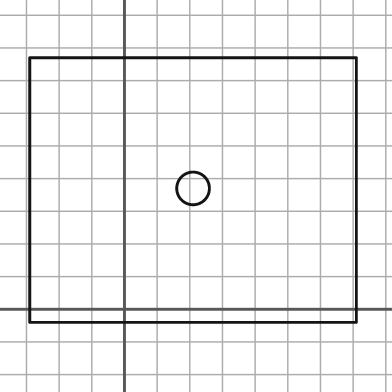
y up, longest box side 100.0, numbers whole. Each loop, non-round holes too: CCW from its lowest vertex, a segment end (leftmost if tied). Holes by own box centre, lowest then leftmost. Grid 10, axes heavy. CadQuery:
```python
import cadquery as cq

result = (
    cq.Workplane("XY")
    .moveTo(-29.0, -4.0)
    .lineTo(71.0, -4.0)
    .lineTo(71.0, 77.0)
    .lineTo(-29.0, 77.0)
    .close()
    .moveTo(21.0, 37.0)
    .circle(5.0)
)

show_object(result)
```